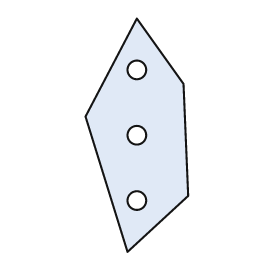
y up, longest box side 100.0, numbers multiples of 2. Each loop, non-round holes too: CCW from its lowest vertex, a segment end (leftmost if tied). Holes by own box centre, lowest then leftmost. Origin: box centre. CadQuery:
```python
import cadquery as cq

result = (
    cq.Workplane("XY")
    .moveTo(-4.0, -50.0)
    .lineTo(22.0, -26.0)
    .lineTo(20.0, 22.0)
    .lineTo(0.0, 50.0)
    .lineTo(-22.0, 8.0)
    .close()
    .moveTo(0.0, -28.0)
    .circle(4.0)
    .moveTo(0.0, 0.0)
    .circle(4.0)
    .moveTo(0.0, 28.0)
    .circle(4.0)
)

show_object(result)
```